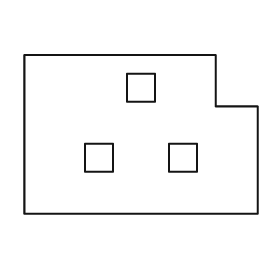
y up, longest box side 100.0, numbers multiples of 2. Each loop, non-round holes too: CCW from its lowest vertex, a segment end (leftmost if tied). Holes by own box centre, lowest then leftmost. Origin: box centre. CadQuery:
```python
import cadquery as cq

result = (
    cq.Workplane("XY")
    .moveTo(-50.0, -34.0)
    .lineTo(50.0, -34.0)
    .lineTo(50.0, 12.0)
    .lineTo(32.0, 12.0)
    .lineTo(32.0, 34.0)
    .lineTo(-50.0, 34.0)
    .close()
    .moveTo(-24.0, -16.0)
    .lineTo(-12.0, -16.0)
    .lineTo(-12.0, -4.0)
    .lineTo(-24.0, -4.0)
    .close()
    .moveTo(12.0, -16.0)
    .lineTo(24.0, -16.0)
    .lineTo(24.0, -4.0)
    .lineTo(12.0, -4.0)
    .close()
    .moveTo(-6.0, 14.0)
    .lineTo(6.0, 14.0)
    .lineTo(6.0, 26.0)
    .lineTo(-6.0, 26.0)
    .close()
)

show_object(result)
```